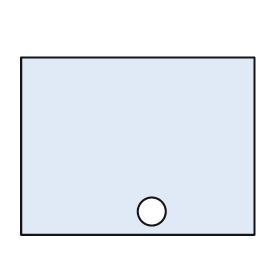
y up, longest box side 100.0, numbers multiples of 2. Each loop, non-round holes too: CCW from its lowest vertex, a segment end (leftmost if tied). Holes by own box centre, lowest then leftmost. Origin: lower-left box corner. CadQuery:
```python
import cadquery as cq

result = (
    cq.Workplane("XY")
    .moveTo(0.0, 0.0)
    .lineTo(100.0, 0.0)
    .lineTo(100.0, 76.0)
    .lineTo(0.0, 76.0)
    .close()
    .moveTo(56.0, 10.0)
    .circle(6.0)
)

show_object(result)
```